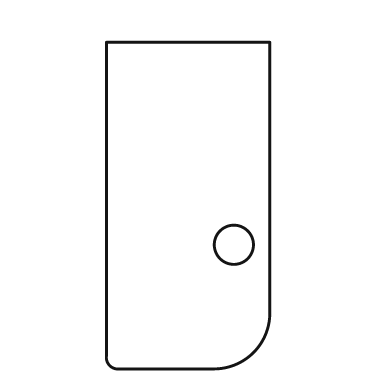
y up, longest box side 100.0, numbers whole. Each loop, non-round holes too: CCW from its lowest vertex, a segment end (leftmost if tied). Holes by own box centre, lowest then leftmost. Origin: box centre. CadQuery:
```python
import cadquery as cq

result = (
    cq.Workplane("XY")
    .moveTo(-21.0, -50.0)
    .lineTo(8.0, -50.0)
    .threePointArc((20.0, -45.0), (25.0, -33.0))
    .lineTo(25.0, 50.0)
    .lineTo(-25.0, 50.0)
    .lineTo(-25.0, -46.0)
    .threePointArc((-24.0, -49.0), (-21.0, -50.0))
    .close()
    .moveTo(14.0, -12.0)
    .circle(6.0)
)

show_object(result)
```